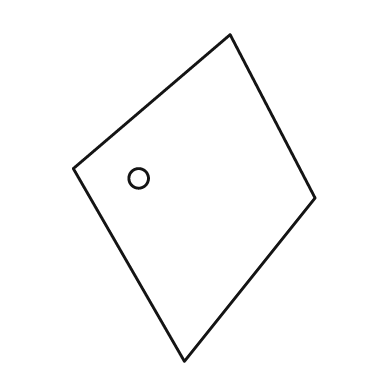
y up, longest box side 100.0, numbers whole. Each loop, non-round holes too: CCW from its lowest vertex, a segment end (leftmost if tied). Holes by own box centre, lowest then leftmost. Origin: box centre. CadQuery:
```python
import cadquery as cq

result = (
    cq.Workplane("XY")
    .moveTo(-3.0, -50.0)
    .lineTo(37.0, 0.0)
    .lineTo(11.0, 50.0)
    .lineTo(-37.0, 9.0)
    .close()
    .moveTo(-17.0, 6.0)
    .circle(3.0)
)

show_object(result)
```